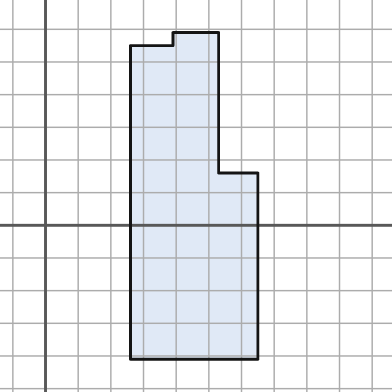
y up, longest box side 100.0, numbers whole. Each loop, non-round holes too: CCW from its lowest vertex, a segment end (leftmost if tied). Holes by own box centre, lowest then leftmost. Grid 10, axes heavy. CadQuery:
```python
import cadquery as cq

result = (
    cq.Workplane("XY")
    .moveTo(26.0, -41.0)
    .lineTo(65.0, -41.0)
    .lineTo(65.0, 16.0)
    .lineTo(53.0, 16.0)
    .lineTo(53.0, 59.0)
    .lineTo(39.0, 59.0)
    .lineTo(39.0, 55.0)
    .lineTo(26.0, 55.0)
    .close()
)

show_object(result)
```